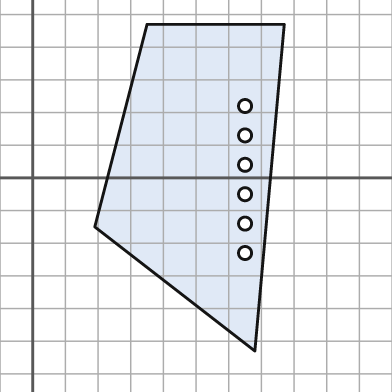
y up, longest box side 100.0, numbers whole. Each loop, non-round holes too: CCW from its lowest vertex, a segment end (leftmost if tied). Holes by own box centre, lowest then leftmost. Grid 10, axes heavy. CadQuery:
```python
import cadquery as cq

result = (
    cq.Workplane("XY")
    .moveTo(68.0, -53.0)
    .lineTo(77.0, 47.0)
    .lineTo(35.0, 47.0)
    .lineTo(19.0, -15.0)
    .close()
    .moveTo(65.0, -23.0)
    .circle(2.0)
    .moveTo(65.0, -14.0)
    .circle(2.0)
    .moveTo(65.0, -5.0)
    .circle(2.0)
    .moveTo(65.0, 4.0)
    .circle(2.0)
    .moveTo(65.0, 13.0)
    .circle(2.0)
    .moveTo(65.0, 22.0)
    .circle(2.0)
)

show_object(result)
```